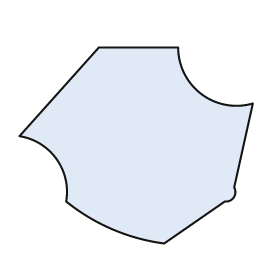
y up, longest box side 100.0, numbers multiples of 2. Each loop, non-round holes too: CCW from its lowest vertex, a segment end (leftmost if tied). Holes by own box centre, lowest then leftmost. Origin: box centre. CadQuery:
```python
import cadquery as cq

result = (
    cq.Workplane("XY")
    .moveTo(12.0, -42.0)
    .lineTo(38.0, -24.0)
    .threePointArc((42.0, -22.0), (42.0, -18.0))
    .lineTo(50.0, 18.0)
    .threePointArc((28.0, 22.0), (18.0, 42.0))
    .lineTo(-16.0, 42.0)
    .lineTo(-50.0, 4.0)
    .threePointArc((-34.0, -6.0), (-30.0, -24.0))
    .threePointArc((-10.0, -36.0), (12.0, -42.0))
    .close()
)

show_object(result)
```